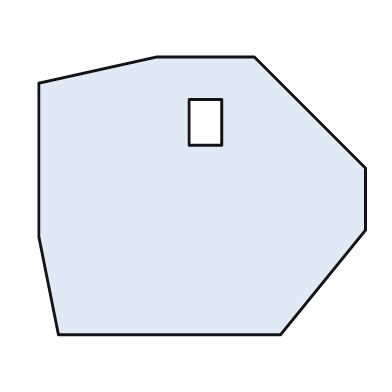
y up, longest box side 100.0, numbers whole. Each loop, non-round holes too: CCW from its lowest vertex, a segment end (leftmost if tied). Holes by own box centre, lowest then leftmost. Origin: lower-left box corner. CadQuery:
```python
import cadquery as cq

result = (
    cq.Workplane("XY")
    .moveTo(6.0, 0.0)
    .lineTo(74.0, 0.0)
    .lineTo(100.0, 32.0)
    .lineTo(100.0, 51.0)
    .lineTo(66.0, 85.0)
    .lineTo(36.0, 85.0)
    .lineTo(0.0, 77.0)
    .lineTo(0.0, 30.0)
    .close()
    .moveTo(46.0, 58.0)
    .lineTo(56.0, 58.0)
    .lineTo(56.0, 72.0)
    .lineTo(46.0, 72.0)
    .close()
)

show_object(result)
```